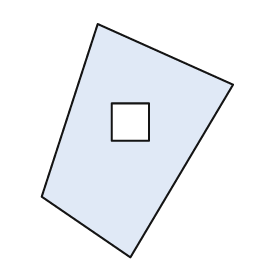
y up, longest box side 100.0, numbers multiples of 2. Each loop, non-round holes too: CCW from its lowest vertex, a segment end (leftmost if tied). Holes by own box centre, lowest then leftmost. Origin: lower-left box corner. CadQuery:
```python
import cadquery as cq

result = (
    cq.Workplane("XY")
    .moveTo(38.0, 0.0)
    .lineTo(82.0, 74.0)
    .lineTo(24.0, 100.0)
    .lineTo(0.0, 26.0)
    .close()
    .moveTo(30.0, 50.0)
    .lineTo(46.0, 50.0)
    .lineTo(46.0, 66.0)
    .lineTo(30.0, 66.0)
    .close()
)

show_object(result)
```